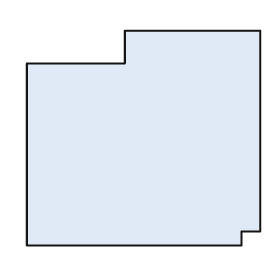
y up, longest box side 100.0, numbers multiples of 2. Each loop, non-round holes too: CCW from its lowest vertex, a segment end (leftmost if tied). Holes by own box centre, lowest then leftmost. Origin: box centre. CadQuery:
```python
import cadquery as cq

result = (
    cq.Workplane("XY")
    .moveTo(-50.0, -46.0)
    .lineTo(42.0, -46.0)
    .lineTo(42.0, -40.0)
    .lineTo(50.0, -40.0)
    .lineTo(50.0, 46.0)
    .lineTo(-8.0, 46.0)
    .lineTo(-8.0, 32.0)
    .lineTo(-50.0, 32.0)
    .close()
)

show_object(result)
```